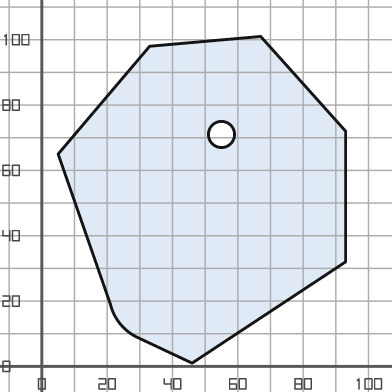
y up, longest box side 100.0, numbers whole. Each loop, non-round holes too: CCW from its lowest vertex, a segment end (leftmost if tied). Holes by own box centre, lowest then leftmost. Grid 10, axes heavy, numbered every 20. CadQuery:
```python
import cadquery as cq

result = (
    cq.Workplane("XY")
    .moveTo(46.0, 1.0)
    .lineTo(93.0, 32.0)
    .lineTo(93.0, 72.0)
    .lineTo(67.0, 101.0)
    .lineTo(33.0, 98.0)
    .lineTo(5.0, 65.0)
    .lineTo(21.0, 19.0)
    .threePointArc((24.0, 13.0), (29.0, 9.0))
    .close()
    .moveTo(55.0, 71.0)
    .circle(4.0)
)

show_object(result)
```